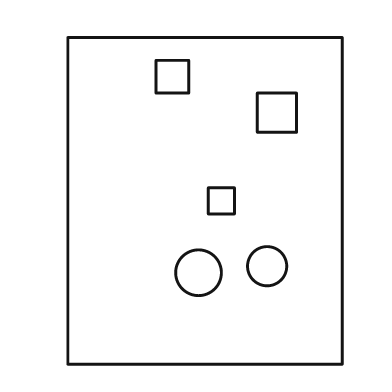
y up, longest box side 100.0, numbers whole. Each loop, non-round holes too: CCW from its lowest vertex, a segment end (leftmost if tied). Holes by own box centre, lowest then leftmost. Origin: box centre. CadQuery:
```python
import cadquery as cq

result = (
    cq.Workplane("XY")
    .moveTo(-42.0, -50.0)
    .lineTo(42.0, -50.0)
    .lineTo(42.0, 50.0)
    .lineTo(-42.0, 50.0)
    .close()
    .moveTo(-2.0, -22.0)
    .circle(7.0)
    .moveTo(19.0, -20.0)
    .circle(6.0)
    .moveTo(1.0, -4.0)
    .lineTo(9.0, -4.0)
    .lineTo(9.0, 4.0)
    .lineTo(1.0, 4.0)
    .close()
    .moveTo(16.0, 21.0)
    .lineTo(28.0, 21.0)
    .lineTo(28.0, 33.0)
    .lineTo(16.0, 33.0)
    .close()
    .moveTo(-15.0, 33.0)
    .lineTo(-5.0, 33.0)
    .lineTo(-5.0, 43.0)
    .lineTo(-15.0, 43.0)
    .close()
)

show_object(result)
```